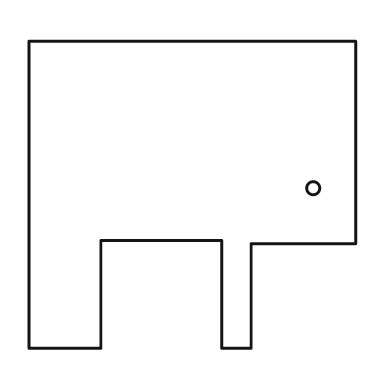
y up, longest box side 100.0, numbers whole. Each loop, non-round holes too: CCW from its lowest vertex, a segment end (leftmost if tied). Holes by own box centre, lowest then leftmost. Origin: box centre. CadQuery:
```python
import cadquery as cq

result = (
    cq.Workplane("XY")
    .moveTo(-50.0, -47.0)
    .lineTo(-28.0, -47.0)
    .lineTo(-28.0, -14.0)
    .lineTo(9.0, -14.0)
    .lineTo(9.0, -47.0)
    .lineTo(18.0, -47.0)
    .lineTo(18.0, -15.0)
    .lineTo(50.0, -15.0)
    .lineTo(50.0, 47.0)
    .lineTo(-50.0, 47.0)
    .close()
    .moveTo(37.0, 2.0)
    .circle(2.0)
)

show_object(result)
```